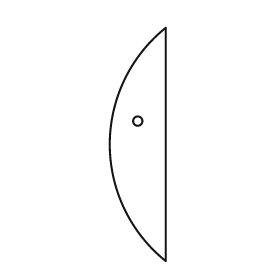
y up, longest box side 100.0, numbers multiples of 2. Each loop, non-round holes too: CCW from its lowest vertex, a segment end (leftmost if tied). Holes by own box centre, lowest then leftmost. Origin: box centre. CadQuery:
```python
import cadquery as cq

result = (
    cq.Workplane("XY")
    .moveTo(12.0, -50.0)
    .lineTo(12.0, 50.0)
    .threePointArc((-12.0, 0.0), (12.0, -50.0))
    .close()
    .moveTo(0.0, 10.0)
    .circle(2.0)
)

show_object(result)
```